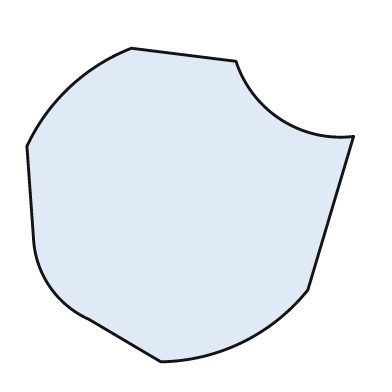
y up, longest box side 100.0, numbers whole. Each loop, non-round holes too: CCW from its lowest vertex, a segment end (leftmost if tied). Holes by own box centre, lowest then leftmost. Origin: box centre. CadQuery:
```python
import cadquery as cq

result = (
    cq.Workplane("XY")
    .moveTo(-9.0, -48.0)
    .threePointArc((16.0, -42.0), (36.0, -26.0))
    .lineTo(50.0, 21.0)
    .threePointArc((28.0, 26.0), (14.0, 44.0))
    .lineTo(-18.0, 48.0)
    .threePointArc((-37.0, 36.0), (-50.0, 18.0))
    .lineTo(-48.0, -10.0)
    .threePointArc((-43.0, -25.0), (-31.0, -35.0))
    .close()
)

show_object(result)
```